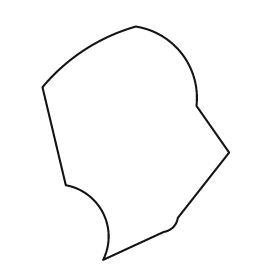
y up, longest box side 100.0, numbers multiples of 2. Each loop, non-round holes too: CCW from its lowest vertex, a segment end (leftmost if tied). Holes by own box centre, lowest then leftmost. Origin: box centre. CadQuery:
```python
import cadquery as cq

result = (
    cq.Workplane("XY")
    .moveTo(-14.0, -50.0)
    .lineTo(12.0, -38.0)
    .threePointArc((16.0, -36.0), (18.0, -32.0))
    .lineTo(40.0, -4.0)
    .lineTo(26.0, 16.0)
    .threePointArc((20.0, 38.0), (0.0, 50.0))
    .threePointArc((-22.0, 40.0), (-40.0, 24.0))
    .lineTo(-30.0, -18.0)
    .threePointArc((-14.0, -30.0), (-14.0, -50.0))
    .close()
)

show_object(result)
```